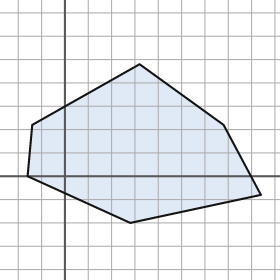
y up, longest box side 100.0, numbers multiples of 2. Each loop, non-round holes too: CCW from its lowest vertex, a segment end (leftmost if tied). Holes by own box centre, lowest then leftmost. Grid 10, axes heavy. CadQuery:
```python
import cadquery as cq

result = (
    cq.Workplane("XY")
    .moveTo(28.0, -20.0)
    .lineTo(84.0, -8.0)
    .lineTo(68.0, 22.0)
    .lineTo(32.0, 48.0)
    .lineTo(-14.0, 22.0)
    .lineTo(-16.0, 0.0)
    .close()
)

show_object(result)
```